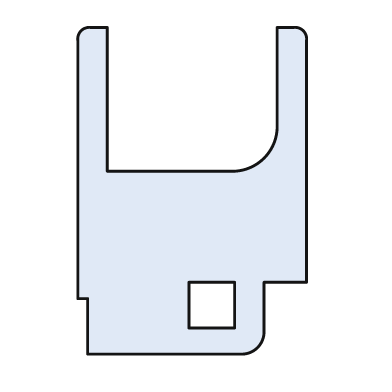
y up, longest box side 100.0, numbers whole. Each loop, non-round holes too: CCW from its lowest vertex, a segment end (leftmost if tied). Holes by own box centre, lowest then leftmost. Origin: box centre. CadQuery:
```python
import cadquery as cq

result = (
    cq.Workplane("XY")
    .moveTo(-32.0, -50.0)
    .lineTo(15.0, -50.0)
    .threePointArc((20.0, -48.0), (22.0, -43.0))
    .lineTo(22.0, -28.0)
    .lineTo(35.0, -28.0)
    .lineTo(35.0, 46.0)
    .threePointArc((34.0, 49.0), (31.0, 50.0))
    .lineTo(26.0, 50.0)
    .lineTo(26.0, 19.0)
    .threePointArc((22.0, 10.0), (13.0, 6.0))
    .lineTo(-26.0, 6.0)
    .lineTo(-26.0, 50.0)
    .lineTo(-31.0, 50.0)
    .threePointArc((-34.0, 49.0), (-35.0, 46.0))
    .lineTo(-35.0, -33.0)
    .lineTo(-32.0, -33.0)
    .close()
    .moveTo(-1.0, -42.0)
    .lineTo(13.0, -42.0)
    .lineTo(13.0, -28.0)
    .lineTo(-1.0, -28.0)
    .close()
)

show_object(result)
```